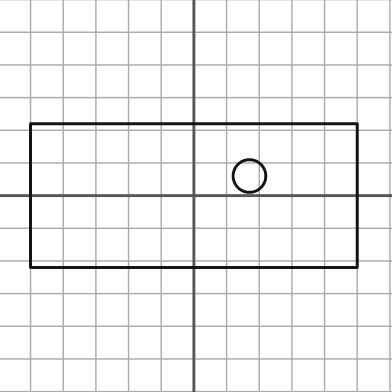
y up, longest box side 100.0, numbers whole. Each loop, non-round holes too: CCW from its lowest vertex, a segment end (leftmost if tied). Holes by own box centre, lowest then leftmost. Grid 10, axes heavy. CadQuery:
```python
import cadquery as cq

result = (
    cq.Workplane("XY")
    .moveTo(-50.0, -22.0)
    .lineTo(50.0, -22.0)
    .lineTo(50.0, 22.0)
    .lineTo(-50.0, 22.0)
    .close()
    .moveTo(17.0, 6.0)
    .circle(5.0)
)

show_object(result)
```